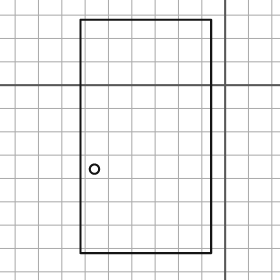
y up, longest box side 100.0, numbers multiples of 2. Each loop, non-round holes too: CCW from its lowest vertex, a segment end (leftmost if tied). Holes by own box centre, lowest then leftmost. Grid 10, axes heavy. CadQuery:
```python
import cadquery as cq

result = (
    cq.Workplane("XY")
    .moveTo(-62.0, -72.0)
    .lineTo(-6.0, -72.0)
    .lineTo(-6.0, 28.0)
    .lineTo(-62.0, 28.0)
    .close()
    .moveTo(-56.0, -36.0)
    .circle(2.0)
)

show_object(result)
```